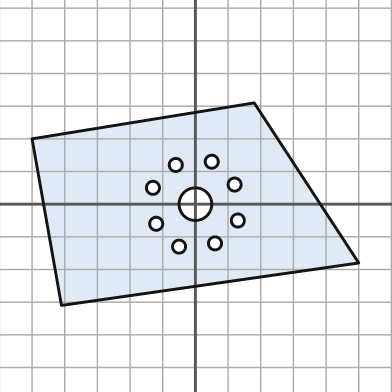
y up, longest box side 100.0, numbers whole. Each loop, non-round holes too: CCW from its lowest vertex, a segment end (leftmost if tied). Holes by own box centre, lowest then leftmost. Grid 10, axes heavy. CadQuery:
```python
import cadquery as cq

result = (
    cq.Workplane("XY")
    .moveTo(-41.0, -31.0)
    .lineTo(50.0, -18.0)
    .lineTo(18.0, 31.0)
    .lineTo(-50.0, 20.0)
    .close()
    .moveTo(-5.0, -13.0)
    .circle(2.0)
    .moveTo(6.0, -12.0)
    .circle(2.0)
    .moveTo(-12.0, -6.0)
    .circle(2.0)
    .moveTo(13.0, -5.0)
    .circle(2.0)
    .moveTo(0.0, 0.0)
    .circle(5.0)
    .moveTo(-13.0, 5.0)
    .circle(2.0)
    .moveTo(12.0, 6.0)
    .circle(2.0)
    .moveTo(-6.0, 12.0)
    .circle(2.0)
    .moveTo(5.0, 13.0)
    .circle(2.0)
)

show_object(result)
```